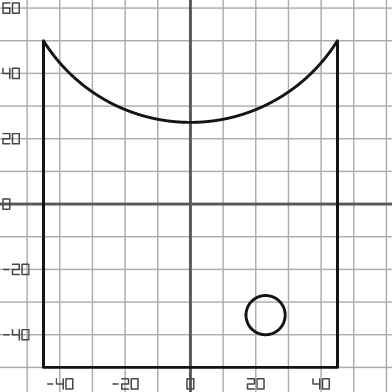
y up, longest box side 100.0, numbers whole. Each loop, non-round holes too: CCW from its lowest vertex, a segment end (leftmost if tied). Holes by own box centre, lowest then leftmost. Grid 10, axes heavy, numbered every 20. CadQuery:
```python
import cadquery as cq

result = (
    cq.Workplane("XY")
    .moveTo(-45.0, -50.0)
    .lineTo(45.0, -50.0)
    .lineTo(45.0, 50.0)
    .threePointArc((0.0, 25.0), (-45.0, 50.0))
    .close()
    .moveTo(23.0, -34.0)
    .circle(6.0)
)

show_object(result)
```